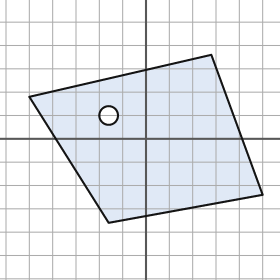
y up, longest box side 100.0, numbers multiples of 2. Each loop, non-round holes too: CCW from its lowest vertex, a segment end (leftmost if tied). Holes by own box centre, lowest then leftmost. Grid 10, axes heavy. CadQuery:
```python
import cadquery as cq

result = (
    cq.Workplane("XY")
    .moveTo(-16.0, -36.0)
    .lineTo(50.0, -24.0)
    .lineTo(28.0, 36.0)
    .lineTo(-50.0, 18.0)
    .close()
    .moveTo(-16.0, 10.0)
    .circle(4.0)
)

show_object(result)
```